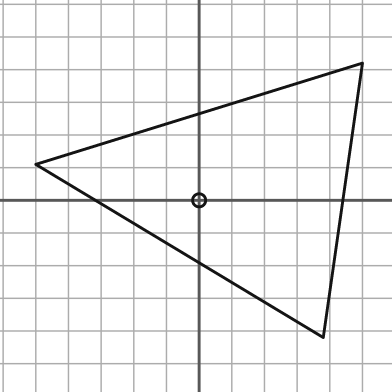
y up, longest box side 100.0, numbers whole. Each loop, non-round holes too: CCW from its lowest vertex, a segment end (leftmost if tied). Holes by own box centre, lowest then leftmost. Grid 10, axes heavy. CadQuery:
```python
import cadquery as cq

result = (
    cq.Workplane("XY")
    .moveTo(38.0, -42.0)
    .lineTo(50.0, 42.0)
    .lineTo(-50.0, 11.0)
    .close()
    .moveTo(0.0, 0.0)
    .circle(2.0)
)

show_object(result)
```